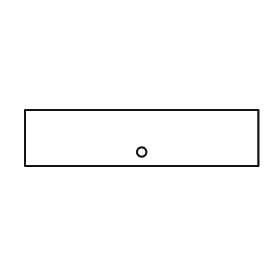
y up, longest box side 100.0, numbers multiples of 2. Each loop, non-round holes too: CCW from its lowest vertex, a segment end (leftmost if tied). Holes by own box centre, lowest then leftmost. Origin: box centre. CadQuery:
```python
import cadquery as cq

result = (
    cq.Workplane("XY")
    .moveTo(-50.0, -12.0)
    .lineTo(50.0, -12.0)
    .lineTo(50.0, 12.0)
    .lineTo(-50.0, 12.0)
    .close()
    .moveTo(0.0, -6.0)
    .circle(2.0)
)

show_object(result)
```